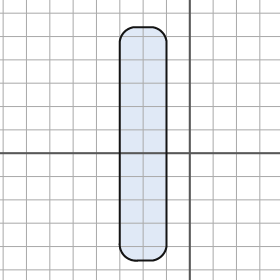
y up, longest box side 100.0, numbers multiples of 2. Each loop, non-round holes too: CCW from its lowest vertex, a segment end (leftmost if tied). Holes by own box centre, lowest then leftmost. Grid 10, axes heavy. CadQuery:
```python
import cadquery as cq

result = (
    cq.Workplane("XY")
    .moveTo(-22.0, -46.0)
    .lineTo(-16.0, -46.0)
    .threePointArc((-12.0, -44.0), (-10.0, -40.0))
    .lineTo(-10.0, 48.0)
    .threePointArc((-12.0, 52.0), (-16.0, 54.0))
    .lineTo(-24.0, 54.0)
    .threePointArc((-28.0, 52.0), (-30.0, 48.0))
    .lineTo(-30.0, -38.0)
    .threePointArc((-28.0, -44.0), (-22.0, -46.0))
    .close()
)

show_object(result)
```